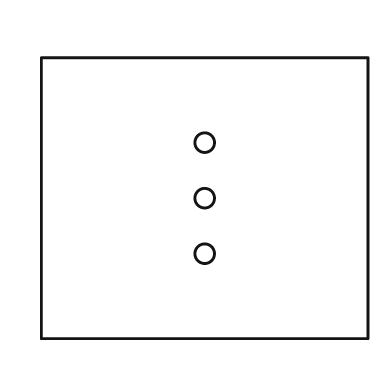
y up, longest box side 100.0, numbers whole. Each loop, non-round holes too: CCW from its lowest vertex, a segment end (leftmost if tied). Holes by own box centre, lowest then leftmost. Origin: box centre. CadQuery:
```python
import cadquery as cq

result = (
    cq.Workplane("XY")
    .moveTo(-50.0, -43.0)
    .lineTo(50.0, -43.0)
    .lineTo(50.0, 43.0)
    .lineTo(-50.0, 43.0)
    .close()
    .moveTo(0.0, -17.0)
    .circle(3.0)
    .moveTo(0.0, 0.0)
    .circle(3.0)
    .moveTo(0.0, 17.0)
    .circle(3.0)
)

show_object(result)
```